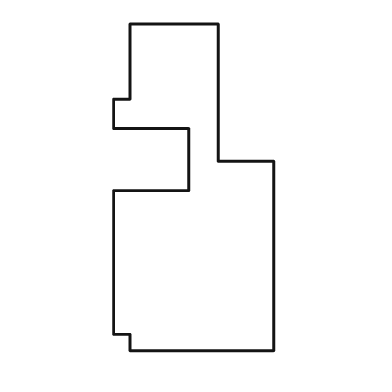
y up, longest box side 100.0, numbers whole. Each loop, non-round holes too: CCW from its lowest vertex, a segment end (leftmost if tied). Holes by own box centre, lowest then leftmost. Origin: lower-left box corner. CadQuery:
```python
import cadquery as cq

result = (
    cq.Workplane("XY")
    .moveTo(5.0, 0.0)
    .lineTo(49.0, 0.0)
    .lineTo(49.0, 58.0)
    .lineTo(32.0, 58.0)
    .lineTo(32.0, 100.0)
    .lineTo(5.0, 100.0)
    .lineTo(5.0, 77.0)
    .lineTo(0.0, 77.0)
    .lineTo(0.0, 68.0)
    .lineTo(23.0, 68.0)
    .lineTo(23.0, 49.0)
    .lineTo(0.0, 49.0)
    .lineTo(0.0, 5.0)
    .lineTo(5.0, 5.0)
    .close()
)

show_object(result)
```